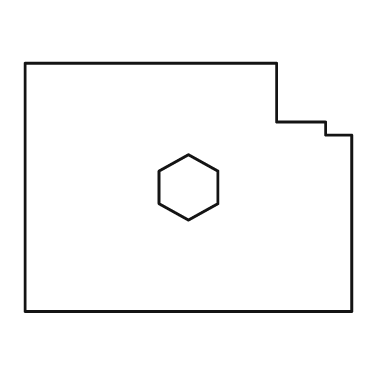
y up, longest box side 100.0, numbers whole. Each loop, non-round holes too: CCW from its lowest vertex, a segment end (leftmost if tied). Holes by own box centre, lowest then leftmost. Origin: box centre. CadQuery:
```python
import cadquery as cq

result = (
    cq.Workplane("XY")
    .moveTo(-50.0, -38.0)
    .lineTo(50.0, -38.0)
    .lineTo(50.0, 16.0)
    .lineTo(42.0, 16.0)
    .lineTo(42.0, 20.0)
    .lineTo(27.0, 20.0)
    .lineTo(27.0, 38.0)
    .lineTo(-50.0, 38.0)
    .close()
    .moveTo(0.0, -10.0)
    .lineTo(9.0, -5.0)
    .lineTo(9.0, 5.0)
    .lineTo(0.0, 10.0)
    .lineTo(-9.0, 5.0)
    .lineTo(-9.0, -5.0)
    .close()
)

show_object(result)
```